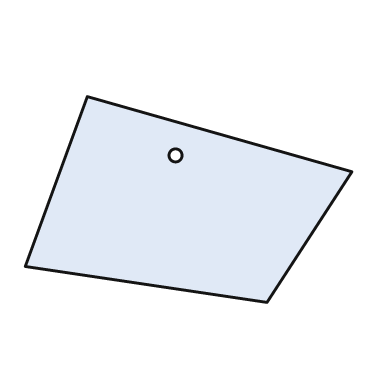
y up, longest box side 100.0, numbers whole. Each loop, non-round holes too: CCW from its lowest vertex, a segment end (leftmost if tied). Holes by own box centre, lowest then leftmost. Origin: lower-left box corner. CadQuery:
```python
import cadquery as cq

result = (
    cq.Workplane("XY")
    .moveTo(74.0, 0.0)
    .lineTo(100.0, 40.0)
    .lineTo(19.0, 63.0)
    .lineTo(0.0, 11.0)
    .close()
    .moveTo(46.0, 45.0)
    .circle(2.0)
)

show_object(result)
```